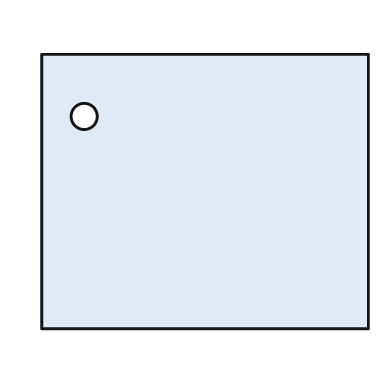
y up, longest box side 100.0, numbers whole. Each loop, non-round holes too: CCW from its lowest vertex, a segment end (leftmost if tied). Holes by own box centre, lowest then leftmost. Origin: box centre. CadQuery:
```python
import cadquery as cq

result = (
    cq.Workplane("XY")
    .moveTo(-50.0, -42.0)
    .lineTo(50.0, -42.0)
    .lineTo(50.0, 42.0)
    .lineTo(-50.0, 42.0)
    .close()
    .moveTo(-37.0, 23.0)
    .circle(4.0)
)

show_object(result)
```